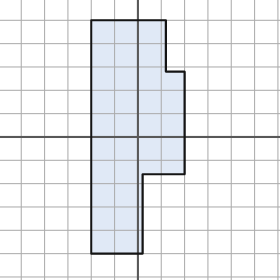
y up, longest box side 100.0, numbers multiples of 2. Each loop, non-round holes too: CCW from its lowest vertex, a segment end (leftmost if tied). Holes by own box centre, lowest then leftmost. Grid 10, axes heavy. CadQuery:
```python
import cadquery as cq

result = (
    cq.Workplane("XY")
    .moveTo(-20.0, -50.0)
    .lineTo(2.0, -50.0)
    .lineTo(2.0, -16.0)
    .lineTo(20.0, -16.0)
    .lineTo(20.0, 28.0)
    .lineTo(12.0, 28.0)
    .lineTo(12.0, 50.0)
    .lineTo(-20.0, 50.0)
    .close()
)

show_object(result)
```